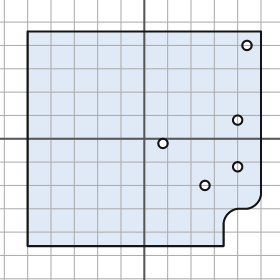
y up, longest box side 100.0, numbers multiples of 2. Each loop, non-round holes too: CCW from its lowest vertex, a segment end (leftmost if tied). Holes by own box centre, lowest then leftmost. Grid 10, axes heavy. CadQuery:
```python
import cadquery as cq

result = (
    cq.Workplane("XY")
    .moveTo(-50.0, -46.0)
    .lineTo(34.0, -46.0)
    .lineTo(34.0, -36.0)
    .threePointArc((36.0, -32.0), (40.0, -30.0))
    .lineTo(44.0, -30.0)
    .threePointArc((48.0, -28.0), (50.0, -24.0))
    .lineTo(50.0, 46.0)
    .lineTo(-50.0, 46.0)
    .close()
    .moveTo(26.0, -20.0)
    .circle(2.0)
    .moveTo(40.0, -12.0)
    .circle(2.0)
    .moveTo(8.0, -2.0)
    .circle(2.0)
    .moveTo(40.0, 8.0)
    .circle(2.0)
    .moveTo(44.0, 40.0)
    .circle(2.0)
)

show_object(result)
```